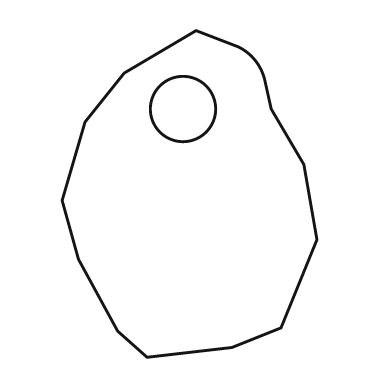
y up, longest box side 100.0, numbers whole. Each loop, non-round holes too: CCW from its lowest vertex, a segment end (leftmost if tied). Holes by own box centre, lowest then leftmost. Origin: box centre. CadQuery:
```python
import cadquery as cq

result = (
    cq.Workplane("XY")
    .moveTo(-13.0, -50.0)
    .lineTo(13.0, -47.0)
    .lineTo(28.0, -41.0)
    .lineTo(39.0, -14.0)
    .lineTo(35.0, 9.0)
    .lineTo(25.0, 26.0)
    .lineTo(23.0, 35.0)
    .threePointArc((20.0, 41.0), (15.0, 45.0))
    .lineTo(2.0, 50.0)
    .lineTo(-20.0, 37.0)
    .lineTo(-32.0, 22.0)
    .lineTo(-39.0, -2.0)
    .lineTo(-34.0, -20.0)
    .lineTo(-22.0, -42.0)
    .close()
    .moveTo(-2.0, 26.0)
    .circle(10.0)
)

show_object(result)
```